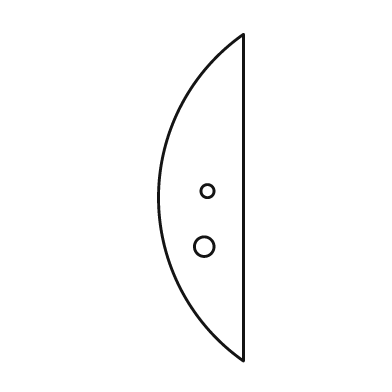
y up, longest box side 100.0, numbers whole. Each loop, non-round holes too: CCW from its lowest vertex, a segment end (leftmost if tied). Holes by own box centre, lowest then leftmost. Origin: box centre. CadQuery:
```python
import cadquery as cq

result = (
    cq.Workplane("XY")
    .moveTo(13.0, -50.0)
    .lineTo(13.0, 50.0)
    .threePointArc((-13.0, 0.0), (13.0, -50.0))
    .close()
    .moveTo(1.0, -15.0)
    .circle(3.0)
    .moveTo(2.0, 2.0)
    .circle(2.0)
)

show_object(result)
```